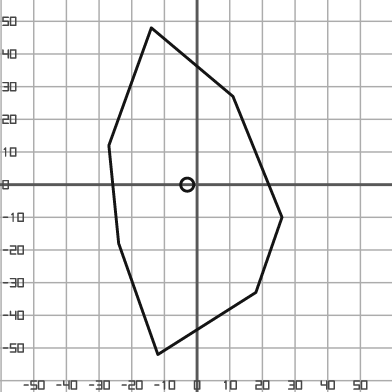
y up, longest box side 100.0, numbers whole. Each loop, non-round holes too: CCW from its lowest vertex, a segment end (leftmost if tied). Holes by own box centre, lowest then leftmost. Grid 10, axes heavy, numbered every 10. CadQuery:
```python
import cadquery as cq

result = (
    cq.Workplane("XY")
    .moveTo(-12.0, -52.0)
    .lineTo(18.0, -33.0)
    .lineTo(26.0, -10.0)
    .lineTo(11.0, 27.0)
    .lineTo(-14.0, 48.0)
    .lineTo(-27.0, 12.0)
    .lineTo(-24.0, -18.0)
    .close()
    .moveTo(-3.0, 0.0)
    .circle(2.0)
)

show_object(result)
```